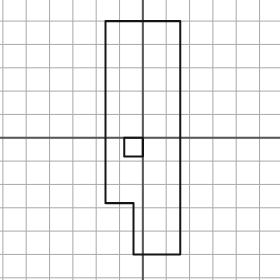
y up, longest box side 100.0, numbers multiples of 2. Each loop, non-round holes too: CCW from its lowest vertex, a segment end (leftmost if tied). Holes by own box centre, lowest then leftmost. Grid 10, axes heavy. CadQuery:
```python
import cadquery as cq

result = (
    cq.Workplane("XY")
    .moveTo(-4.0, -50.0)
    .lineTo(16.0, -50.0)
    .lineTo(16.0, 50.0)
    .lineTo(-16.0, 50.0)
    .lineTo(-16.0, -28.0)
    .lineTo(-4.0, -28.0)
    .close()
    .moveTo(-8.0, -8.0)
    .lineTo(0.0, -8.0)
    .lineTo(0.0, 0.0)
    .lineTo(-8.0, 0.0)
    .close()
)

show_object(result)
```